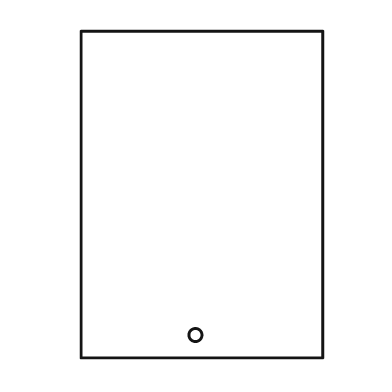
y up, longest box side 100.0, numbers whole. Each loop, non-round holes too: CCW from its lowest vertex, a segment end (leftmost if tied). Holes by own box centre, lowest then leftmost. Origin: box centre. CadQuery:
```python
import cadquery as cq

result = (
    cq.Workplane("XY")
    .moveTo(-37.0, -50.0)
    .lineTo(37.0, -50.0)
    .lineTo(37.0, 50.0)
    .lineTo(-37.0, 50.0)
    .close()
    .moveTo(-2.0, -43.0)
    .circle(2.0)
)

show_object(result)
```